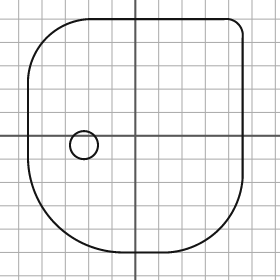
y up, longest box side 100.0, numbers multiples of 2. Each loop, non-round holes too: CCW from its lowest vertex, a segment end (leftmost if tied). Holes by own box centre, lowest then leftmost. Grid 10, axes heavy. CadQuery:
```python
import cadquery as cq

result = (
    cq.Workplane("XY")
    .moveTo(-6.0, -50.0)
    .lineTo(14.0, -50.0)
    .threePointArc((36.0, -40.0), (46.0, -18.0))
    .lineTo(46.0, 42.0)
    .threePointArc((44.0, 48.0), (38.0, 50.0))
    .lineTo(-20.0, 50.0)
    .threePointArc((-38.0, 42.0), (-46.0, 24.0))
    .lineTo(-46.0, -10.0)
    .threePointArc((-34.0, -38.0), (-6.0, -50.0))
    .close()
    .moveTo(-22.0, -4.0)
    .circle(6.0)
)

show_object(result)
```